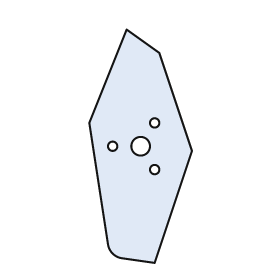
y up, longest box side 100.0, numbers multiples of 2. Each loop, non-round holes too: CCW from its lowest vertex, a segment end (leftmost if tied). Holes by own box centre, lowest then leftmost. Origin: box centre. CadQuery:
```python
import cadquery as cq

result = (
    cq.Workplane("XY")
    .moveTo(6.0, -50.0)
    .lineTo(22.0, -2.0)
    .lineTo(8.0, 40.0)
    .lineTo(-6.0, 50.0)
    .lineTo(-22.0, 10.0)
    .lineTo(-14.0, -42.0)
    .threePointArc((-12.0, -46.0), (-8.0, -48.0))
    .close()
    .moveTo(6.0, -10.0)
    .circle(2.0)
    .moveTo(-12.0, 0.0)
    .circle(2.0)
    .moveTo(0.0, 0.0)
    .circle(4.0)
    .moveTo(6.0, 10.0)
    .circle(2.0)
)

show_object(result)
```